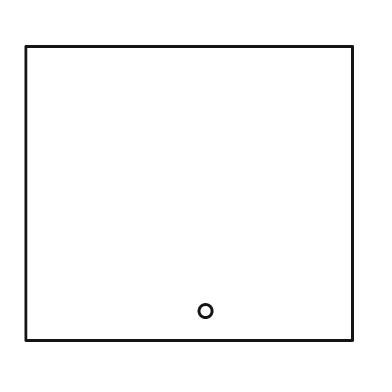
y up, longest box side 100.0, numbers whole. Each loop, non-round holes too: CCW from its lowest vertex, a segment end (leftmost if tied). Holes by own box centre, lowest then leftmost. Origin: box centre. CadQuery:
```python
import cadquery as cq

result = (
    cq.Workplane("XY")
    .moveTo(-50.0, -45.0)
    .lineTo(50.0, -45.0)
    .lineTo(50.0, 45.0)
    .lineTo(-50.0, 45.0)
    .close()
    .moveTo(5.0, -36.0)
    .circle(2.0)
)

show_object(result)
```